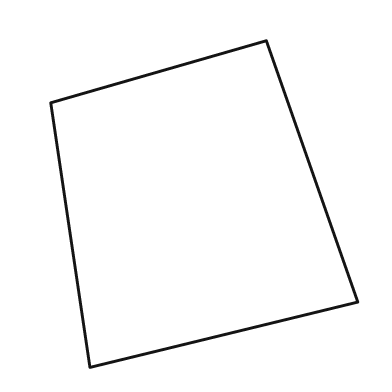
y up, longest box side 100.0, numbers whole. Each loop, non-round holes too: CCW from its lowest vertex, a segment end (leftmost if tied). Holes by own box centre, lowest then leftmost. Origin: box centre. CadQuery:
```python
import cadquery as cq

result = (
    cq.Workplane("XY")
    .moveTo(-35.0, -50.0)
    .lineTo(47.0, -30.0)
    .lineTo(19.0, 50.0)
    .lineTo(-47.0, 31.0)
    .close()
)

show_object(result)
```